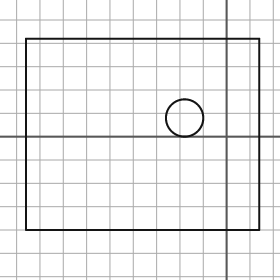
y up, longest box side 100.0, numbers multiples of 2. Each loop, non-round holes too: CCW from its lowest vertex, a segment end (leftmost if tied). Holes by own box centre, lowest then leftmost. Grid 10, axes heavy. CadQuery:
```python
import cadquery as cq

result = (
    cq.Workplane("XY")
    .moveTo(-86.0, -40.0)
    .lineTo(14.0, -40.0)
    .lineTo(14.0, 42.0)
    .lineTo(-86.0, 42.0)
    .close()
    .moveTo(-18.0, 8.0)
    .circle(8.0)
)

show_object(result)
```